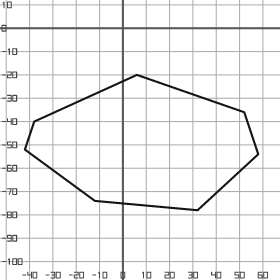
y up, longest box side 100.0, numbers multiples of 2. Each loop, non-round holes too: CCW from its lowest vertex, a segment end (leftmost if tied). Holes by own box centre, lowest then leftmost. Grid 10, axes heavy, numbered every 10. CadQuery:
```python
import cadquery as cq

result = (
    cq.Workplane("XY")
    .moveTo(32.0, -78.0)
    .lineTo(58.0, -54.0)
    .lineTo(52.0, -36.0)
    .lineTo(6.0, -20.0)
    .lineTo(-38.0, -40.0)
    .lineTo(-42.0, -52.0)
    .lineTo(-12.0, -74.0)
    .close()
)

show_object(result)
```